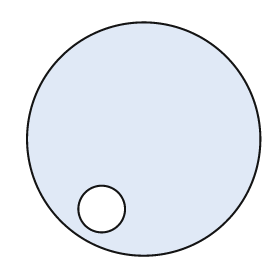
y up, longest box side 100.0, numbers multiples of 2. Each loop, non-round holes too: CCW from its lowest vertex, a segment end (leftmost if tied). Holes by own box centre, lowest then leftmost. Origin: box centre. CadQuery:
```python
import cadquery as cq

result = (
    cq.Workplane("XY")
    .moveTo(0.0, 0.0)
    .circle(50.0)
    .moveTo(-18.0, -30.0)
    .circle(10.0)
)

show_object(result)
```